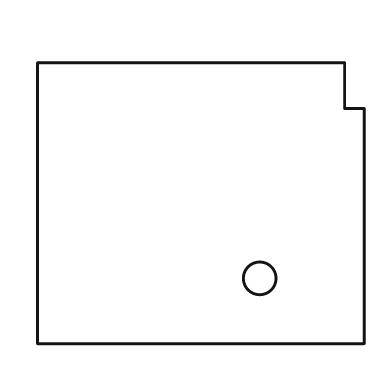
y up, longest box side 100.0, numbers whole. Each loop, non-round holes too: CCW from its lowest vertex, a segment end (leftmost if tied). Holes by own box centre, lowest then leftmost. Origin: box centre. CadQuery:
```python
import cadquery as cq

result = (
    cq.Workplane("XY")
    .moveTo(-50.0, -43.0)
    .lineTo(50.0, -43.0)
    .lineTo(50.0, 29.0)
    .lineTo(44.0, 29.0)
    .lineTo(44.0, 43.0)
    .lineTo(-50.0, 43.0)
    .close()
    .moveTo(18.0, -23.0)
    .circle(5.0)
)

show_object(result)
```